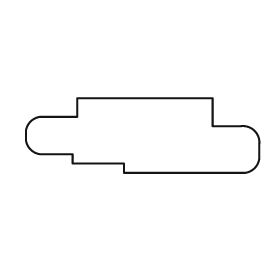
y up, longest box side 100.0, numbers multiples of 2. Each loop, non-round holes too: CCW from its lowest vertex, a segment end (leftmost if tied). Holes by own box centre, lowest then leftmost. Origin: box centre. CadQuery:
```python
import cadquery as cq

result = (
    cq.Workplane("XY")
    .moveTo(-8.0, -16.0)
    .lineTo(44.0, -16.0)
    .threePointArc((48.0, -14.0), (50.0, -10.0))
    .lineTo(50.0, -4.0)
    .threePointArc((48.0, 2.0), (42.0, 4.0))
    .lineTo(30.0, 4.0)
    .lineTo(30.0, 16.0)
    .lineTo(-28.0, 16.0)
    .lineTo(-28.0, 8.0)
    .lineTo(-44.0, 8.0)
    .threePointArc((-48.0, 6.0), (-50.0, 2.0))
    .lineTo(-50.0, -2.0)
    .threePointArc((-48.0, -6.0), (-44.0, -8.0))
    .lineTo(-30.0, -8.0)
    .lineTo(-30.0, -12.0)
    .lineTo(-8.0, -12.0)
    .close()
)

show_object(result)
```